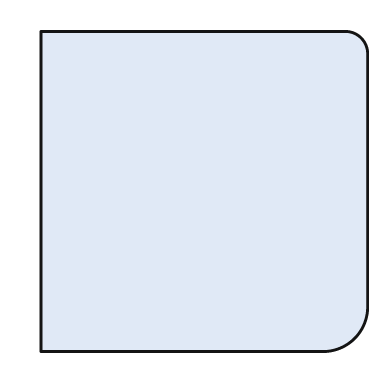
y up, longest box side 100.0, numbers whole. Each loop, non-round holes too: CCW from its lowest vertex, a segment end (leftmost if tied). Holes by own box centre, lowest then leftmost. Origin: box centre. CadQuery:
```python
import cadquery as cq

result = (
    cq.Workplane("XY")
    .moveTo(-50.0, -49.0)
    .lineTo(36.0, -49.0)
    .threePointArc((46.0, -45.0), (50.0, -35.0))
    .lineTo(50.0, 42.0)
    .threePointArc((48.0, 47.0), (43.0, 49.0))
    .lineTo(-50.0, 49.0)
    .close()
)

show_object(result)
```